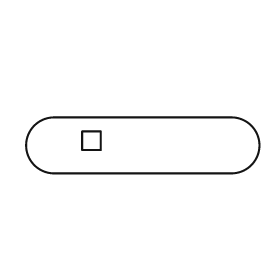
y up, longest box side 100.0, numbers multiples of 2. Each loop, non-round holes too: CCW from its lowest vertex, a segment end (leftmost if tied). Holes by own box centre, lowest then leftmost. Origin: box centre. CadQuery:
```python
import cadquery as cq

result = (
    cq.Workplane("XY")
    .moveTo(-38.0, -12.0)
    .lineTo(38.0, -12.0)
    .threePointArc((50.0, 0.0), (38.0, 12.0))
    .lineTo(-38.0, 12.0)
    .threePointArc((-50.0, 0.0), (-38.0, -12.0))
    .close()
    .moveTo(-26.0, -2.0)
    .lineTo(-18.0, -2.0)
    .lineTo(-18.0, 6.0)
    .lineTo(-26.0, 6.0)
    .close()
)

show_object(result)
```